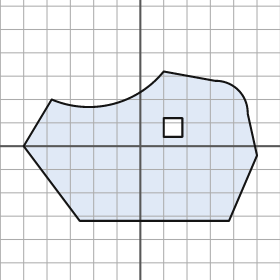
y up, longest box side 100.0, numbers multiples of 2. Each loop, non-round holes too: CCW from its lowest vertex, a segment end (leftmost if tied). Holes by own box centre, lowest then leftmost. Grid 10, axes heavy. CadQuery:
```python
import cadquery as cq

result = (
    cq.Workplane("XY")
    .moveTo(-26.0, -32.0)
    .lineTo(38.0, -32.0)
    .lineTo(50.0, -4.0)
    .lineTo(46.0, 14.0)
    .threePointArc((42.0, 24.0), (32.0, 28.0))
    .lineTo(10.0, 32.0)
    .threePointArc((-12.0, 18.0), (-38.0, 20.0))
    .lineTo(-50.0, 0.0)
    .close()
    .moveTo(10.0, 4.0)
    .lineTo(18.0, 4.0)
    .lineTo(18.0, 12.0)
    .lineTo(10.0, 12.0)
    .close()
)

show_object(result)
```